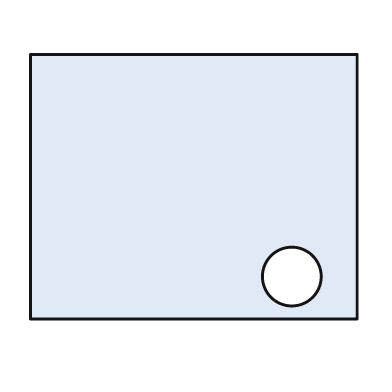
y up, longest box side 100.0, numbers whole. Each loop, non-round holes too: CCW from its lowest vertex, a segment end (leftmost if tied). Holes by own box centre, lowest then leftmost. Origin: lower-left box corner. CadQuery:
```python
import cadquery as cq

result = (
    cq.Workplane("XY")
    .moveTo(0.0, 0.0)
    .lineTo(100.0, 0.0)
    .lineTo(100.0, 81.0)
    .lineTo(0.0, 81.0)
    .close()
    .moveTo(80.0, 13.0)
    .circle(9.0)
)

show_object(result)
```